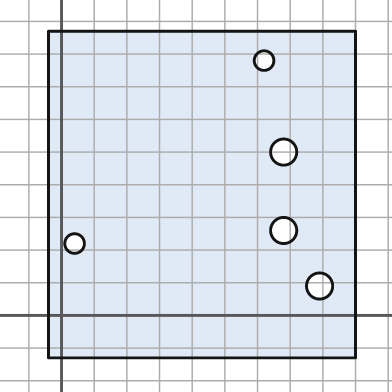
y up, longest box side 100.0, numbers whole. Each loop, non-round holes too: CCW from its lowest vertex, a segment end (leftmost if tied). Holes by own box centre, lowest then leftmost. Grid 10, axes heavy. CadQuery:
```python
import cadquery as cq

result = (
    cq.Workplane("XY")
    .moveTo(-4.0, -13.0)
    .lineTo(90.0, -13.0)
    .lineTo(90.0, 87.0)
    .lineTo(-4.0, 87.0)
    .close()
    .moveTo(79.0, 9.0)
    .circle(4.0)
    .moveTo(4.0, 22.0)
    .circle(3.0)
    .moveTo(68.0, 26.0)
    .circle(4.0)
    .moveTo(68.0, 50.0)
    .circle(4.0)
    .moveTo(62.0, 78.0)
    .circle(3.0)
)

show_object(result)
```